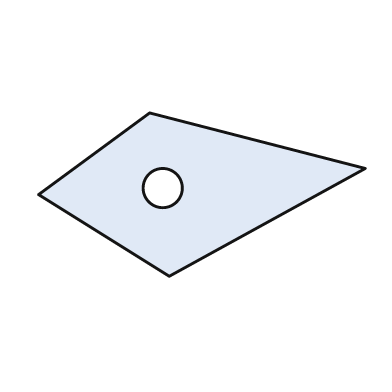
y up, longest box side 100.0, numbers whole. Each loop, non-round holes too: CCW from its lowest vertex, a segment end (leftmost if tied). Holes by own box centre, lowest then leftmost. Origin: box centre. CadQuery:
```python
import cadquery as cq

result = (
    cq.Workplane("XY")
    .moveTo(-10.0, -25.0)
    .lineTo(50.0, 8.0)
    .lineTo(-16.0, 25.0)
    .lineTo(-50.0, 0.0)
    .close()
    .moveTo(-12.0, 2.0)
    .circle(6.0)
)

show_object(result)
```